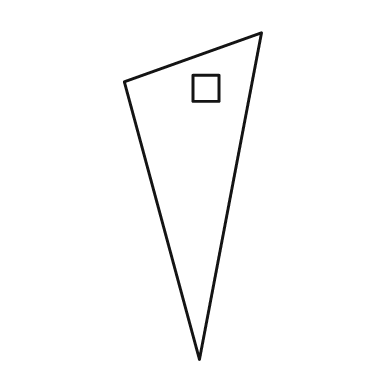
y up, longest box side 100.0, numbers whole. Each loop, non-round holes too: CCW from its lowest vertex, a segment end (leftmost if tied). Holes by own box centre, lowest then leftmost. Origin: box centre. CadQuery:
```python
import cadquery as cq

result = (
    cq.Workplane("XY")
    .moveTo(2.0, -50.0)
    .lineTo(21.0, 50.0)
    .lineTo(-21.0, 35.0)
    .close()
    .moveTo(0.0, 29.0)
    .lineTo(8.0, 29.0)
    .lineTo(8.0, 37.0)
    .lineTo(0.0, 37.0)
    .close()
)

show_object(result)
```